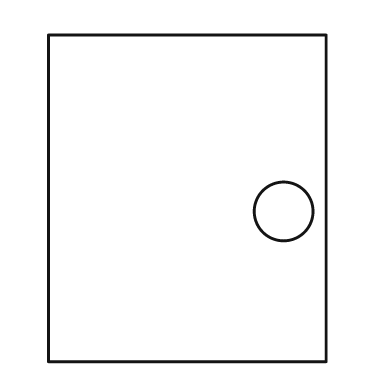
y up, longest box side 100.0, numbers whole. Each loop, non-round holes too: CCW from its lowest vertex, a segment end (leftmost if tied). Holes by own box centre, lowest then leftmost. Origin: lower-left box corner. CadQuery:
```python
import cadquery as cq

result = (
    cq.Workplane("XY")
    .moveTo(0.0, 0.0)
    .lineTo(85.0, 0.0)
    .lineTo(85.0, 100.0)
    .lineTo(0.0, 100.0)
    .close()
    .moveTo(72.0, 46.0)
    .circle(9.0)
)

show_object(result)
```